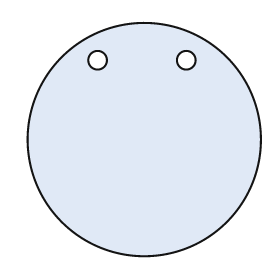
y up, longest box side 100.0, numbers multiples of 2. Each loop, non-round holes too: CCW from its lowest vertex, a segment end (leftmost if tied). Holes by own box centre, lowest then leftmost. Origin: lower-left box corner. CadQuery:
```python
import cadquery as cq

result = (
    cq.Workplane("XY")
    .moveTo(50.0, 50.0)
    .circle(50.0)
    .moveTo(30.0, 84.0)
    .circle(4.0)
    .moveTo(68.0, 84.0)
    .circle(4.0)
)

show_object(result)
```